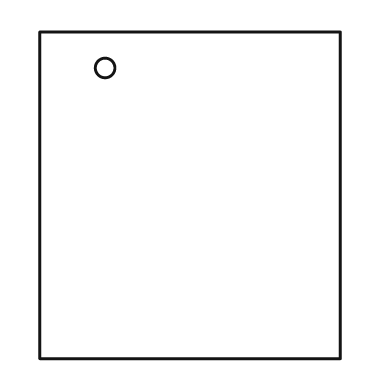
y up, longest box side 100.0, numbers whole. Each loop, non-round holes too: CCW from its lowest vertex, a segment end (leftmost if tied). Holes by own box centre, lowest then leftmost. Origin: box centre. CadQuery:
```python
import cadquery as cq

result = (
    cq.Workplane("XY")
    .moveTo(-46.0, -50.0)
    .lineTo(46.0, -50.0)
    .lineTo(46.0, 50.0)
    .lineTo(-46.0, 50.0)
    .close()
    .moveTo(-26.0, 39.0)
    .circle(3.0)
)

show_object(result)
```